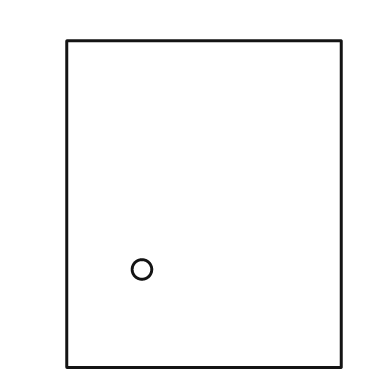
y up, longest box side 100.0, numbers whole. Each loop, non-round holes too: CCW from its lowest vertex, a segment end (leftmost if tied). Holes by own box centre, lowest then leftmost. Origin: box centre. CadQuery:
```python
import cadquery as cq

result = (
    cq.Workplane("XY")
    .moveTo(-42.0, -50.0)
    .lineTo(42.0, -50.0)
    .lineTo(42.0, 50.0)
    .lineTo(-42.0, 50.0)
    .close()
    .moveTo(-19.0, -20.0)
    .circle(3.0)
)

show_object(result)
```